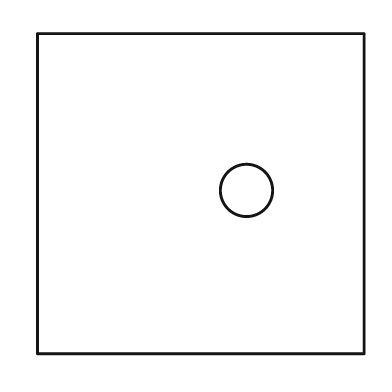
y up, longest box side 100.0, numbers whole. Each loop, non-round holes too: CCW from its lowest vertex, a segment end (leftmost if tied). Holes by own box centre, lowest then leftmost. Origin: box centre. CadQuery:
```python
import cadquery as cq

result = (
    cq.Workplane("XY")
    .moveTo(-50.0, -49.0)
    .lineTo(50.0, -49.0)
    .lineTo(50.0, 49.0)
    .lineTo(-50.0, 49.0)
    .close()
    .moveTo(14.0, 1.0)
    .circle(8.0)
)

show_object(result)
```